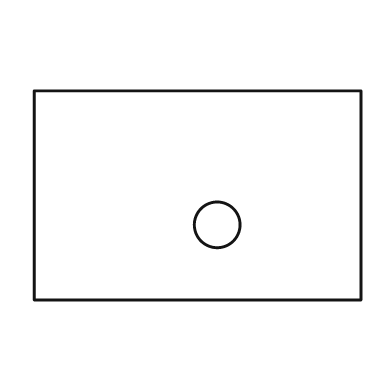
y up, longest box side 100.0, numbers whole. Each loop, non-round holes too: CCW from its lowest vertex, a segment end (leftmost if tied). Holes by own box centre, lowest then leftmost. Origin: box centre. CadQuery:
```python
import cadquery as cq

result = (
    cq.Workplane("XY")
    .moveTo(-50.0, -32.0)
    .lineTo(50.0, -32.0)
    .lineTo(50.0, 32.0)
    .lineTo(-50.0, 32.0)
    .close()
    .moveTo(6.0, -9.0)
    .circle(7.0)
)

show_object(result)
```